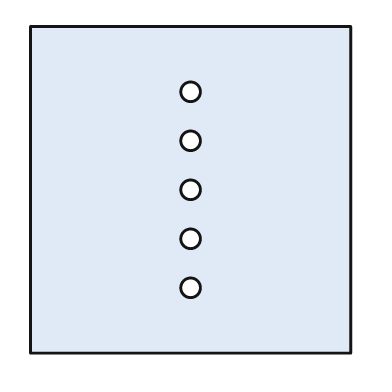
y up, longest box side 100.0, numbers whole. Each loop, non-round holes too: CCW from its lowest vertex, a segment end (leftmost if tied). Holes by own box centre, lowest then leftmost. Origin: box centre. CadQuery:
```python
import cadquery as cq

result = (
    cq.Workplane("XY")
    .moveTo(-49.0, -50.0)
    .lineTo(49.0, -50.0)
    .lineTo(49.0, 50.0)
    .lineTo(-49.0, 50.0)
    .close()
    .moveTo(0.0, -30.0)
    .circle(3.0)
    .moveTo(0.0, -15.0)
    .circle(3.0)
    .moveTo(0.0, 0.0)
    .circle(3.0)
    .moveTo(0.0, 15.0)
    .circle(3.0)
    .moveTo(0.0, 30.0)
    .circle(3.0)
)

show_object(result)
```